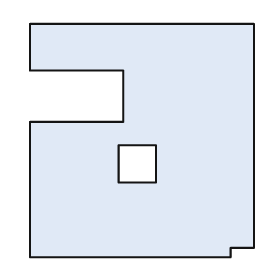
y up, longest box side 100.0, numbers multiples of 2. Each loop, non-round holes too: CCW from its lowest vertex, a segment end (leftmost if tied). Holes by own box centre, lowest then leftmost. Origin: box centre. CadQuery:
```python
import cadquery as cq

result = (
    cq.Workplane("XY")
    .moveTo(-48.0, -50.0)
    .lineTo(38.0, -50.0)
    .lineTo(38.0, -46.0)
    .lineTo(48.0, -46.0)
    .lineTo(48.0, 50.0)
    .lineTo(-48.0, 50.0)
    .lineTo(-48.0, 30.0)
    .lineTo(-8.0, 30.0)
    .lineTo(-8.0, 8.0)
    .lineTo(-48.0, 8.0)
    .close()
    .moveTo(-10.0, -18.0)
    .lineTo(6.0, -18.0)
    .lineTo(6.0, -2.0)
    .lineTo(-10.0, -2.0)
    .close()
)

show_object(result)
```